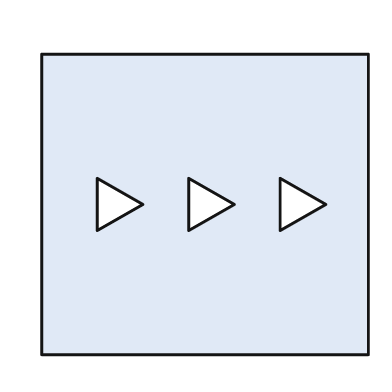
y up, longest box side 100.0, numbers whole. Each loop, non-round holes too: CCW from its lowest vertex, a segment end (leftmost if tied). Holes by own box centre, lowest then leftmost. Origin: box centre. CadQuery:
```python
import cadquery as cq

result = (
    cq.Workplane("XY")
    .moveTo(-50.0, -46.0)
    .lineTo(50.0, -46.0)
    .lineTo(50.0, 46.0)
    .lineTo(-50.0, 46.0)
    .close()
    .moveTo(-33.0, -8.0)
    .lineTo(-19.0, 0.0)
    .lineTo(-33.0, 8.0)
    .close()
    .moveTo(-5.0, -8.0)
    .lineTo(9.0, 0.0)
    .lineTo(-5.0, 8.0)
    .close()
    .moveTo(23.0, -8.0)
    .lineTo(37.0, 0.0)
    .lineTo(23.0, 8.0)
    .close()
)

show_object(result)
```